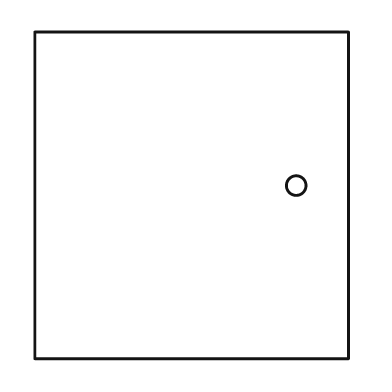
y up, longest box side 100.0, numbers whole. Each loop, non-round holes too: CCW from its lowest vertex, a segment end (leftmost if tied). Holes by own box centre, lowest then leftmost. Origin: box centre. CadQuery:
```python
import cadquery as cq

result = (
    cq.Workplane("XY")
    .moveTo(-48.0, -50.0)
    .lineTo(48.0, -50.0)
    .lineTo(48.0, 50.0)
    .lineTo(-48.0, 50.0)
    .close()
    .moveTo(32.0, 3.0)
    .circle(3.0)
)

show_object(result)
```